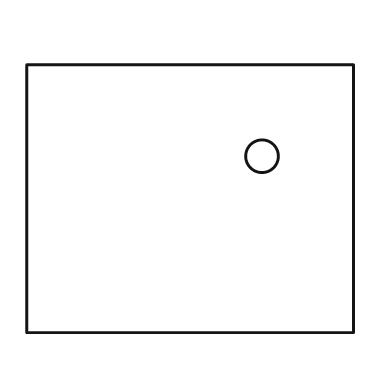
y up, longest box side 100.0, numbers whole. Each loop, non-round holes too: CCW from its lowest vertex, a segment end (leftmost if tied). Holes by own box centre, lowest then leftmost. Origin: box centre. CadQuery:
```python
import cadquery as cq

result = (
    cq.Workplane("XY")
    .moveTo(-50.0, -41.0)
    .lineTo(50.0, -41.0)
    .lineTo(50.0, 41.0)
    .lineTo(-50.0, 41.0)
    .close()
    .moveTo(22.0, 13.0)
    .circle(5.0)
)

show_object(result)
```